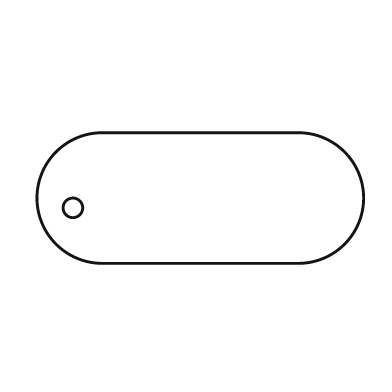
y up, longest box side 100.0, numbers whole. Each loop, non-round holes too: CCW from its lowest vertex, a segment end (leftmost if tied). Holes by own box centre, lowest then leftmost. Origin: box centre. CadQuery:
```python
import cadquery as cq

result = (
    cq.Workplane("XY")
    .moveTo(-30.0, -20.0)
    .lineTo(30.0, -20.0)
    .threePointArc((50.0, 0.0), (30.0, 20.0))
    .lineTo(-30.0, 20.0)
    .threePointArc((-50.0, 0.0), (-30.0, -20.0))
    .close()
    .moveTo(-39.0, -3.0)
    .circle(3.0)
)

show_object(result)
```